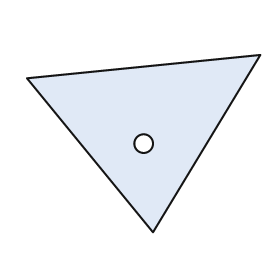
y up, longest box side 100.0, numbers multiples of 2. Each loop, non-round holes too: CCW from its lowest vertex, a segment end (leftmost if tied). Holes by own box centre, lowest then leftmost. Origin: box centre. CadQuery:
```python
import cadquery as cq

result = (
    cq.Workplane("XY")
    .moveTo(4.0, -38.0)
    .lineTo(50.0, 38.0)
    .lineTo(-50.0, 28.0)
    .close()
    .moveTo(0.0, 0.0)
    .circle(4.0)
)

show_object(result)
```